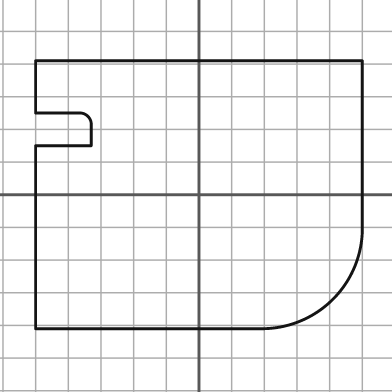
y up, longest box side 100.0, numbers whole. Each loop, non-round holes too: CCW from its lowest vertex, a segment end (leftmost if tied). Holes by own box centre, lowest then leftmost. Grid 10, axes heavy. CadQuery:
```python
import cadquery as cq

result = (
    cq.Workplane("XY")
    .moveTo(-50.0, -41.0)
    .lineTo(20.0, -41.0)
    .threePointArc((41.0, -32.0), (50.0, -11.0))
    .lineTo(50.0, 41.0)
    .lineTo(-50.0, 41.0)
    .lineTo(-50.0, 25.0)
    .lineTo(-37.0, 25.0)
    .threePointArc((-34.0, 24.0), (-33.0, 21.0))
    .lineTo(-33.0, 15.0)
    .lineTo(-50.0, 15.0)
    .close()
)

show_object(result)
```